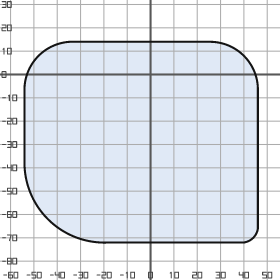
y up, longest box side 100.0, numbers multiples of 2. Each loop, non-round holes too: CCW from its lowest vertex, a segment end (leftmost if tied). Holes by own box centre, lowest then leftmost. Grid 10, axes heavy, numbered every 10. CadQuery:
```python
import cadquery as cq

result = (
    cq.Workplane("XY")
    .moveTo(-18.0, -72.0)
    .lineTo(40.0, -72.0)
    .threePointArc((44.0, -70.0), (46.0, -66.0))
    .lineTo(46.0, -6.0)
    .threePointArc((40.0, 8.0), (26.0, 14.0))
    .lineTo(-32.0, 14.0)
    .threePointArc((-48.0, 8.0), (-54.0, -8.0))
    .lineTo(-54.0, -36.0)
    .threePointArc((-44.0, -62.0), (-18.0, -72.0))
    .close()
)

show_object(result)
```